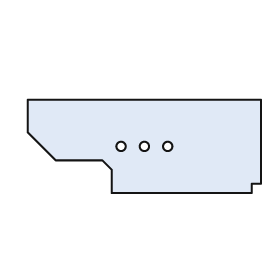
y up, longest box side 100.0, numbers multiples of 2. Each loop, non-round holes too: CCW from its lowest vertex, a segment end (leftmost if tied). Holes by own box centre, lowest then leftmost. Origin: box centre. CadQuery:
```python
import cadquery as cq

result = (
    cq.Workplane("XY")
    .moveTo(-14.0, -20.0)
    .lineTo(46.0, -20.0)
    .lineTo(46.0, -16.0)
    .lineTo(50.0, -16.0)
    .lineTo(50.0, 20.0)
    .lineTo(-50.0, 20.0)
    .lineTo(-50.0, 6.0)
    .lineTo(-38.0, -6.0)
    .lineTo(-18.0, -6.0)
    .lineTo(-14.0, -10.0)
    .close()
    .moveTo(-10.0, 0.0)
    .circle(2.0)
    .moveTo(0.0, 0.0)
    .circle(2.0)
    .moveTo(10.0, 0.0)
    .circle(2.0)
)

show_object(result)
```